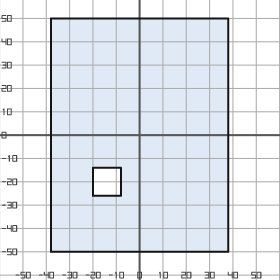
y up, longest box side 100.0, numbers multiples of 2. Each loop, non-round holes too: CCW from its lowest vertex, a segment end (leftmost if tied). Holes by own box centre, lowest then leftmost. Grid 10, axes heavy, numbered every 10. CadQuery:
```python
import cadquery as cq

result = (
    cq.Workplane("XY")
    .moveTo(-38.0, -50.0)
    .lineTo(38.0, -50.0)
    .lineTo(38.0, 50.0)
    .lineTo(-38.0, 50.0)
    .close()
    .moveTo(-20.0, -26.0)
    .lineTo(-8.0, -26.0)
    .lineTo(-8.0, -14.0)
    .lineTo(-20.0, -14.0)
    .close()
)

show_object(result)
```